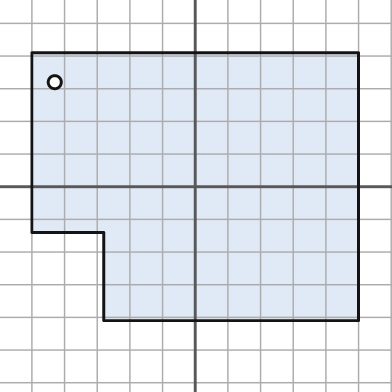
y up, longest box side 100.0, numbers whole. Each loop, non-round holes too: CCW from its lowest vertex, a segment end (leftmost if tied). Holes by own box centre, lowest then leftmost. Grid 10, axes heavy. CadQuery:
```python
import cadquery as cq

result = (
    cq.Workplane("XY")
    .moveTo(-28.0, -41.0)
    .lineTo(50.0, -41.0)
    .lineTo(50.0, 41.0)
    .lineTo(-50.0, 41.0)
    .lineTo(-50.0, -14.0)
    .lineTo(-28.0, -14.0)
    .close()
    .moveTo(-43.0, 32.0)
    .circle(2.0)
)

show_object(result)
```